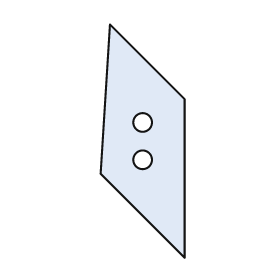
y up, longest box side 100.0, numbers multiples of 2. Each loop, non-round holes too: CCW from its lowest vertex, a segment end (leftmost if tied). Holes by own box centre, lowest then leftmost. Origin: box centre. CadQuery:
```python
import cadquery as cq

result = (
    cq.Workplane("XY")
    .moveTo(18.0, -50.0)
    .lineTo(18.0, 18.0)
    .lineTo(-14.0, 50.0)
    .lineTo(-18.0, -14.0)
    .close()
    .moveTo(0.0, -8.0)
    .circle(4.0)
    .moveTo(0.0, 8.0)
    .circle(4.0)
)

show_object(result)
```